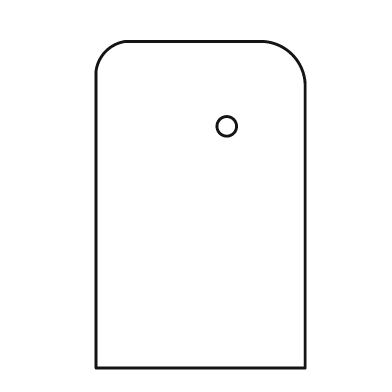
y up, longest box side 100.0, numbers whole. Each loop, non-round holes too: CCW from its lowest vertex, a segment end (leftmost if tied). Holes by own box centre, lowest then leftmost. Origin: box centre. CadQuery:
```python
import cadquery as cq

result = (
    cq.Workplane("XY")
    .moveTo(-32.0, -50.0)
    .lineTo(32.0, -50.0)
    .lineTo(32.0, 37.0)
    .threePointArc((28.0, 46.0), (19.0, 50.0))
    .lineTo(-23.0, 50.0)
    .threePointArc((-29.0, 47.0), (-32.0, 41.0))
    .close()
    .moveTo(8.0, 24.0)
    .circle(3.0)
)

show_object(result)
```